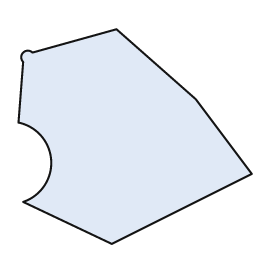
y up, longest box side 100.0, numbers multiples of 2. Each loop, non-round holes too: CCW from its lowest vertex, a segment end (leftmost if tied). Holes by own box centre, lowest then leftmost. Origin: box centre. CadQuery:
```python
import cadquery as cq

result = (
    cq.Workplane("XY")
    .moveTo(-10.0, -46.0)
    .lineTo(50.0, -16.0)
    .lineTo(26.0, 16.0)
    .lineTo(-8.0, 46.0)
    .lineTo(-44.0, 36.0)
    .threePointArc((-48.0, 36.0), (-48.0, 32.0))
    .lineTo(-50.0, 6.0)
    .threePointArc((-36.0, -10.0), (-48.0, -28.0))
    .close()
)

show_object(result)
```